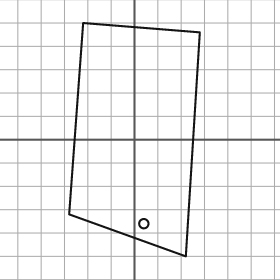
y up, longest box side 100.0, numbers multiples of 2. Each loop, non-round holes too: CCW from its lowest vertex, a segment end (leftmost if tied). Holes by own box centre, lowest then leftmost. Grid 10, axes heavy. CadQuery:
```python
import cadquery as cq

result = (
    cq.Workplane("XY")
    .moveTo(22.0, -50.0)
    .lineTo(28.0, 46.0)
    .lineTo(-22.0, 50.0)
    .lineTo(-28.0, -32.0)
    .close()
    .moveTo(4.0, -36.0)
    .circle(2.0)
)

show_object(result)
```